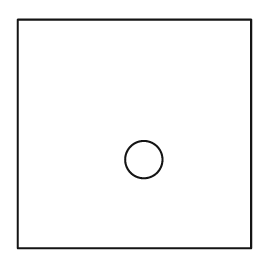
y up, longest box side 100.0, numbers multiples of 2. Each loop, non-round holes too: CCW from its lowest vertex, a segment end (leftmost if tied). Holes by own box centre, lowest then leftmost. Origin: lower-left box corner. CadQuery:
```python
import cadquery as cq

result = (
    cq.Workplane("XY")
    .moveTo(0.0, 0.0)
    .lineTo(100.0, 0.0)
    .lineTo(100.0, 98.0)
    .lineTo(0.0, 98.0)
    .close()
    .moveTo(54.0, 38.0)
    .circle(8.0)
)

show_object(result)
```